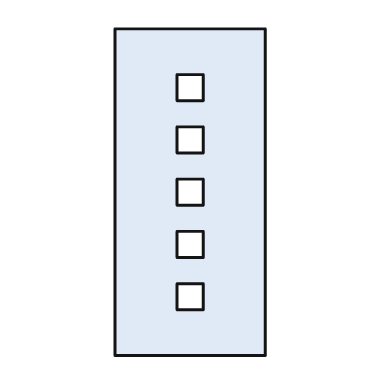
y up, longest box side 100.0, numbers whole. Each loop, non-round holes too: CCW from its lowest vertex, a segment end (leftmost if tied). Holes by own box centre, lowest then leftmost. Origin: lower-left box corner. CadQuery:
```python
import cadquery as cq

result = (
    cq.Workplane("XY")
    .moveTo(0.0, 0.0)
    .lineTo(46.0, 0.0)
    .lineTo(46.0, 100.0)
    .lineTo(0.0, 100.0)
    .close()
    .moveTo(19.0, 14.0)
    .lineTo(27.0, 14.0)
    .lineTo(27.0, 22.0)
    .lineTo(19.0, 22.0)
    .close()
    .moveTo(19.0, 30.0)
    .lineTo(27.0, 30.0)
    .lineTo(27.0, 38.0)
    .lineTo(19.0, 38.0)
    .close()
    .moveTo(19.0, 46.0)
    .lineTo(27.0, 46.0)
    .lineTo(27.0, 54.0)
    .lineTo(19.0, 54.0)
    .close()
    .moveTo(19.0, 62.0)
    .lineTo(27.0, 62.0)
    .lineTo(27.0, 70.0)
    .lineTo(19.0, 70.0)
    .close()
    .moveTo(19.0, 78.0)
    .lineTo(27.0, 78.0)
    .lineTo(27.0, 86.0)
    .lineTo(19.0, 86.0)
    .close()
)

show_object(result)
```